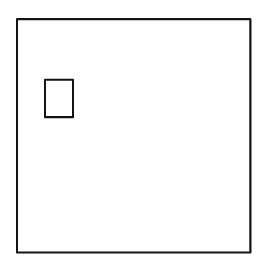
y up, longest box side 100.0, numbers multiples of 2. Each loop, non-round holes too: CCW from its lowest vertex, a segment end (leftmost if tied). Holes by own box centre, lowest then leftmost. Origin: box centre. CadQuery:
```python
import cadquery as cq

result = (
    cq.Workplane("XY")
    .moveTo(-50.0, -50.0)
    .lineTo(50.0, -50.0)
    .lineTo(50.0, 50.0)
    .lineTo(-50.0, 50.0)
    .close()
    .moveTo(-38.0, 8.0)
    .lineTo(-26.0, 8.0)
    .lineTo(-26.0, 24.0)
    .lineTo(-38.0, 24.0)
    .close()
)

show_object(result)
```